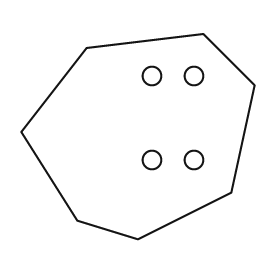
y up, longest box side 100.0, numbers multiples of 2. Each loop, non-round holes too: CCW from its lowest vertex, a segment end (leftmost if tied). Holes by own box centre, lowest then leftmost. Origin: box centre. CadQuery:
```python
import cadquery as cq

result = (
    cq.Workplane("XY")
    .moveTo(0.0, -44.0)
    .lineTo(40.0, -24.0)
    .lineTo(50.0, 22.0)
    .lineTo(28.0, 44.0)
    .lineTo(-22.0, 38.0)
    .lineTo(-50.0, 2.0)
    .lineTo(-26.0, -36.0)
    .close()
    .moveTo(6.0, -10.0)
    .circle(4.0)
    .moveTo(24.0, -10.0)
    .circle(4.0)
    .moveTo(6.0, 26.0)
    .circle(4.0)
    .moveTo(24.0, 26.0)
    .circle(4.0)
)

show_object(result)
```